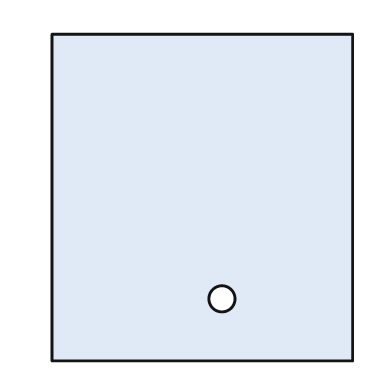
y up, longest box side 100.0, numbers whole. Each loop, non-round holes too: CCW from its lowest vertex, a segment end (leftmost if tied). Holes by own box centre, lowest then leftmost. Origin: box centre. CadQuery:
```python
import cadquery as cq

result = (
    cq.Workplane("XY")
    .moveTo(-46.0, -50.0)
    .lineTo(46.0, -50.0)
    .lineTo(46.0, 50.0)
    .lineTo(-46.0, 50.0)
    .close()
    .moveTo(6.0, -31.0)
    .circle(4.0)
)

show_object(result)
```